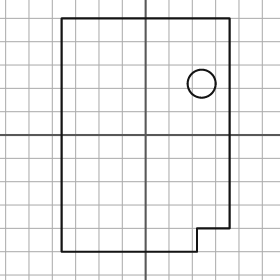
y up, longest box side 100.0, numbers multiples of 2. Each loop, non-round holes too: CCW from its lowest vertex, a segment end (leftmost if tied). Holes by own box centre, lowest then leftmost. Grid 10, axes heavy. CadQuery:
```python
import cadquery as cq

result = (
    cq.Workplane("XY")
    .moveTo(-36.0, -50.0)
    .lineTo(22.0, -50.0)
    .lineTo(22.0, -40.0)
    .lineTo(36.0, -40.0)
    .lineTo(36.0, 50.0)
    .lineTo(-36.0, 50.0)
    .close()
    .moveTo(24.0, 22.0)
    .circle(6.0)
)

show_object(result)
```